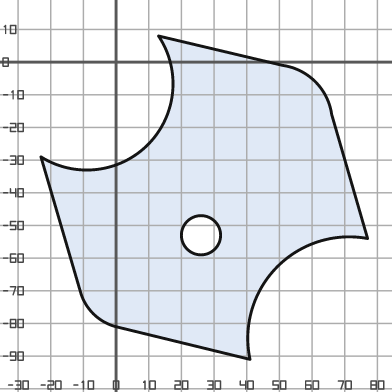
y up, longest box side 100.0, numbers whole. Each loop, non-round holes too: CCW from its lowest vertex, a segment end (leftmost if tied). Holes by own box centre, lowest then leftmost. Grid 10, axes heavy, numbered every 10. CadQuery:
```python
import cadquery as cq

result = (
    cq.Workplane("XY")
    .moveTo(41.0, -91.0)
    .threePointArc((49.0, -63.0), (77.0, -54.0))
    .lineTo(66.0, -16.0)
    .threePointArc((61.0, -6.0), (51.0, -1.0))
    .lineTo(13.0, 8.0)
    .threePointArc((10.0, -25.0), (-23.0, -29.0))
    .lineTo(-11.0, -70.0)
    .threePointArc((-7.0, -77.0), (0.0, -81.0))
    .close()
    .moveTo(26.0, -53.0)
    .circle(6.0)
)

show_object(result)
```